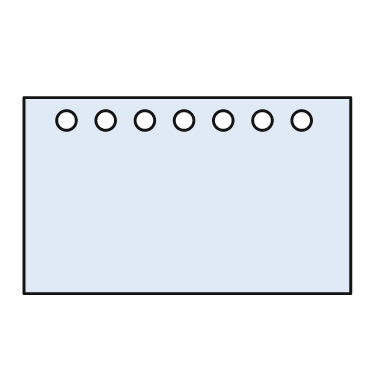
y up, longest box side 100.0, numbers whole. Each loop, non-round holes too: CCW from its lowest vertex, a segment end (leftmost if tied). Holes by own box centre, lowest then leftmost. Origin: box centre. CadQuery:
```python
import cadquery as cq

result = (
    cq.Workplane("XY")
    .moveTo(-50.0, -30.0)
    .lineTo(50.0, -30.0)
    .lineTo(50.0, 30.0)
    .lineTo(-50.0, 30.0)
    .close()
    .moveTo(-37.0, 23.0)
    .circle(3.0)
    .moveTo(-25.0, 23.0)
    .circle(3.0)
    .moveTo(-13.0, 23.0)
    .circle(3.0)
    .moveTo(-1.0, 23.0)
    .circle(3.0)
    .moveTo(11.0, 23.0)
    .circle(3.0)
    .moveTo(23.0, 23.0)
    .circle(3.0)
    .moveTo(35.0, 23.0)
    .circle(3.0)
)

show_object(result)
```